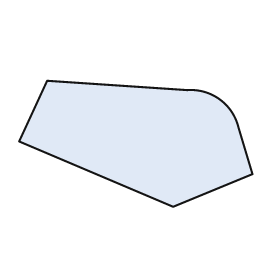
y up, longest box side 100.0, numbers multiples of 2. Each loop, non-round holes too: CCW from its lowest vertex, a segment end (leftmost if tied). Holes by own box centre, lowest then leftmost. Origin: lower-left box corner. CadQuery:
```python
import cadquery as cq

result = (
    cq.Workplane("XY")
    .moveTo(66.0, 0.0)
    .lineTo(100.0, 14.0)
    .lineTo(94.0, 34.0)
    .threePointArc((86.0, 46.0), (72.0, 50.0))
    .lineTo(12.0, 54.0)
    .lineTo(0.0, 28.0)
    .close()
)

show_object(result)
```